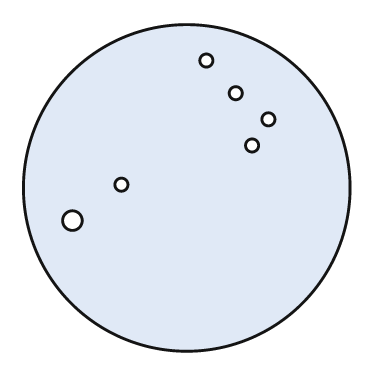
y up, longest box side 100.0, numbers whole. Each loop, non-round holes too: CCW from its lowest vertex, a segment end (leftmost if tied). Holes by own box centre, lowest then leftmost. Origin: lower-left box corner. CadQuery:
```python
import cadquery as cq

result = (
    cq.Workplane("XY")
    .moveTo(50.0, 50.0)
    .circle(50.0)
    .moveTo(15.0, 40.0)
    .circle(3.0)
    .moveTo(30.0, 51.0)
    .circle(2.0)
    .moveTo(70.0, 63.0)
    .circle(2.0)
    .moveTo(75.0, 71.0)
    .circle(2.0)
    .moveTo(65.0, 79.0)
    .circle(2.0)
    .moveTo(56.0, 89.0)
    .circle(2.0)
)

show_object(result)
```